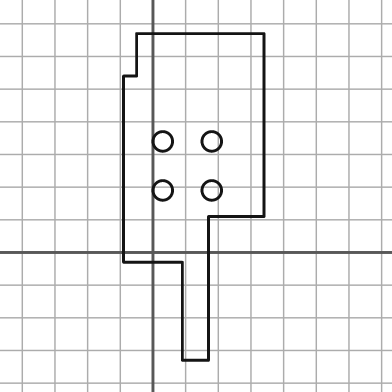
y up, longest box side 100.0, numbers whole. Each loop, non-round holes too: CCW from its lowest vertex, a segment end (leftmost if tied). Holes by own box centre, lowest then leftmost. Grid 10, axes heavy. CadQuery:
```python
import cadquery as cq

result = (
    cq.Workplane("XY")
    .moveTo(9.0, -33.0)
    .lineTo(17.0, -33.0)
    .lineTo(17.0, 11.0)
    .lineTo(34.0, 11.0)
    .lineTo(34.0, 67.0)
    .lineTo(-5.0, 67.0)
    .lineTo(-5.0, 54.0)
    .lineTo(-9.0, 54.0)
    .lineTo(-9.0, -3.0)
    .lineTo(9.0, -3.0)
    .close()
    .moveTo(3.0, 19.0)
    .circle(3.0)
    .moveTo(18.0, 19.0)
    .circle(3.0)
    .moveTo(3.0, 34.0)
    .circle(3.0)
    .moveTo(18.0, 34.0)
    .circle(3.0)
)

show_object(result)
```